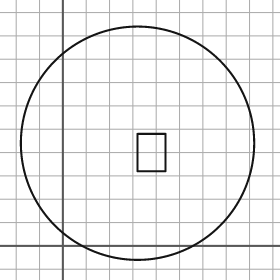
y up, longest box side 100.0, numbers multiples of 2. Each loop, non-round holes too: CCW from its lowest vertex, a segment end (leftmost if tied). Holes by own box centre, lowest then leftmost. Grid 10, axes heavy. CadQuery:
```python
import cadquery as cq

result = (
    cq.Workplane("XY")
    .moveTo(32.0, 44.0)
    .circle(50.0)
    .moveTo(32.0, 32.0)
    .lineTo(44.0, 32.0)
    .lineTo(44.0, 48.0)
    .lineTo(32.0, 48.0)
    .close()
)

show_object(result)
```